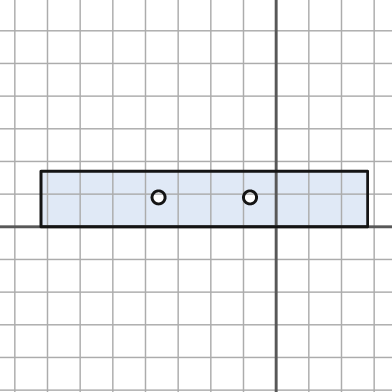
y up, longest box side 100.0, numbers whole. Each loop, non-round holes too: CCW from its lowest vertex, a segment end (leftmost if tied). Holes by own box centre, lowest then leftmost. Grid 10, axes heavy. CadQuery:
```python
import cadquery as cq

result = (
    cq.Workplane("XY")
    .moveTo(-72.0, 0.0)
    .lineTo(28.0, 0.0)
    .lineTo(28.0, 17.0)
    .lineTo(-72.0, 17.0)
    .close()
    .moveTo(-36.0, 9.0)
    .circle(2.0)
    .moveTo(-8.0, 9.0)
    .circle(2.0)
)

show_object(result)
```